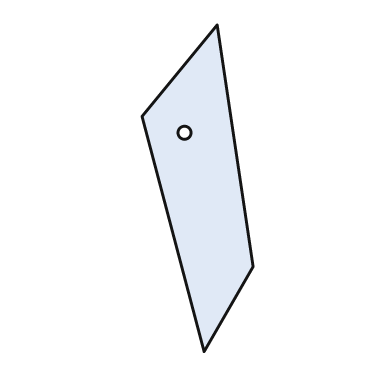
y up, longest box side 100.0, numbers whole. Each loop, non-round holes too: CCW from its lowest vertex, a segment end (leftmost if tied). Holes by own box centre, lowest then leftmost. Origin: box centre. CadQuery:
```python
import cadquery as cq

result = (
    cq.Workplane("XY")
    .moveTo(2.0, -50.0)
    .lineTo(17.0, -24.0)
    .lineTo(6.0, 50.0)
    .lineTo(-17.0, 22.0)
    .close()
    .moveTo(-4.0, 17.0)
    .circle(2.0)
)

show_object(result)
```